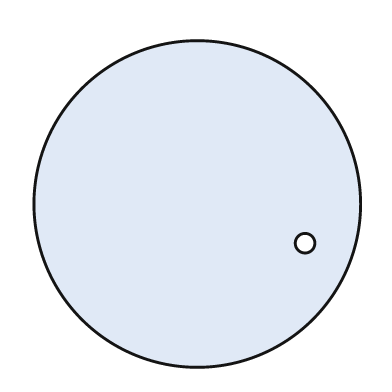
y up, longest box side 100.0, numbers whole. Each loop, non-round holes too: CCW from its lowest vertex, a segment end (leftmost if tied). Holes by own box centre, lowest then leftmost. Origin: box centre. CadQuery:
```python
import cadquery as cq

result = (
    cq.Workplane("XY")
    .moveTo(0.0, 0.0)
    .circle(50.0)
    .moveTo(33.0, -12.0)
    .circle(3.0)
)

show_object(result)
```